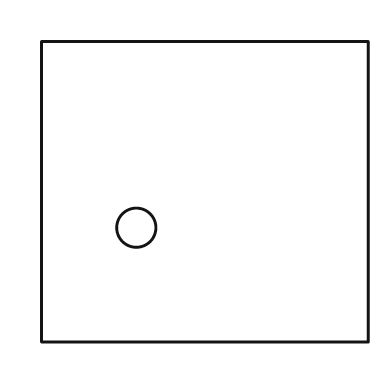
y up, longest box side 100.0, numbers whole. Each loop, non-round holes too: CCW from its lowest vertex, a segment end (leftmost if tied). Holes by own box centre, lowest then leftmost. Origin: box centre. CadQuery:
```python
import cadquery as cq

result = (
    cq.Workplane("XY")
    .moveTo(-50.0, -46.0)
    .lineTo(50.0, -46.0)
    .lineTo(50.0, 46.0)
    .lineTo(-50.0, 46.0)
    .close()
    .moveTo(-21.0, -11.0)
    .circle(6.0)
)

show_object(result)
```